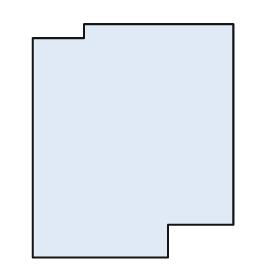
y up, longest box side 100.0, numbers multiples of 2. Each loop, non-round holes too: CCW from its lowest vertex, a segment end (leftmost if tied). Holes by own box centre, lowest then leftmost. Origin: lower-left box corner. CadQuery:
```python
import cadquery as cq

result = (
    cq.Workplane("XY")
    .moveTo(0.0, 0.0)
    .lineTo(58.0, 0.0)
    .lineTo(58.0, 14.0)
    .lineTo(86.0, 14.0)
    .lineTo(86.0, 100.0)
    .lineTo(22.0, 100.0)
    .lineTo(22.0, 94.0)
    .lineTo(0.0, 94.0)
    .close()
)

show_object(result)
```